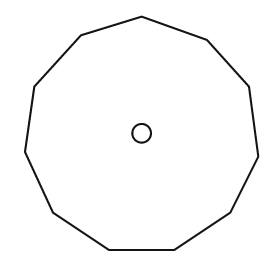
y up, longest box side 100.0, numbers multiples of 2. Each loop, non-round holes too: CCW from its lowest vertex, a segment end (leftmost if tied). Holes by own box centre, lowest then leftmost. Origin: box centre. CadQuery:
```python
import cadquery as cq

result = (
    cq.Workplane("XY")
    .moveTo(-14.0, -50.0)
    .lineTo(14.0, -50.0)
    .lineTo(38.0, -34.0)
    .lineTo(50.0, -10.0)
    .lineTo(46.0, 20.0)
    .lineTo(28.0, 40.0)
    .lineTo(0.0, 50.0)
    .lineTo(-26.0, 42.0)
    .lineTo(-46.0, 20.0)
    .lineTo(-50.0, -8.0)
    .lineTo(-38.0, -34.0)
    .close()
    .moveTo(0.0, 0.0)
    .circle(4.0)
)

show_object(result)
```